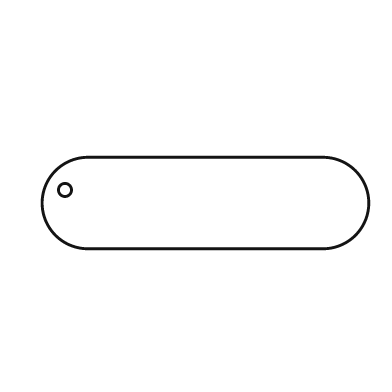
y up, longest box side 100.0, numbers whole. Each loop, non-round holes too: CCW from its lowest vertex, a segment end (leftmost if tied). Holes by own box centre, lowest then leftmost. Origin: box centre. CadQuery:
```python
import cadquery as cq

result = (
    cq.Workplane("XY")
    .moveTo(-36.0, -14.0)
    .lineTo(36.0, -14.0)
    .threePointArc((50.0, 0.0), (36.0, 14.0))
    .lineTo(-36.0, 14.0)
    .threePointArc((-50.0, 0.0), (-36.0, -14.0))
    .close()
    .moveTo(-43.0, 4.0)
    .circle(2.0)
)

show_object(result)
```